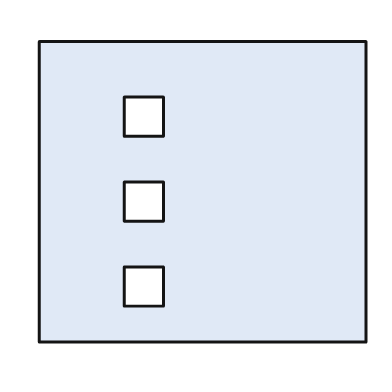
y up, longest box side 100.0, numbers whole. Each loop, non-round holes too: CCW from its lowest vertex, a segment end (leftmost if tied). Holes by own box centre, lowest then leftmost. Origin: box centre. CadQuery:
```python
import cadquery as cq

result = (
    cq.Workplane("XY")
    .moveTo(-50.0, -46.0)
    .lineTo(50.0, -46.0)
    .lineTo(50.0, 46.0)
    .lineTo(-50.0, 46.0)
    .close()
    .moveTo(-24.0, -35.0)
    .lineTo(-12.0, -35.0)
    .lineTo(-12.0, -23.0)
    .lineTo(-24.0, -23.0)
    .close()
    .moveTo(-24.0, -9.0)
    .lineTo(-12.0, -9.0)
    .lineTo(-12.0, 3.0)
    .lineTo(-24.0, 3.0)
    .close()
    .moveTo(-24.0, 17.0)
    .lineTo(-12.0, 17.0)
    .lineTo(-12.0, 29.0)
    .lineTo(-24.0, 29.0)
    .close()
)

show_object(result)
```